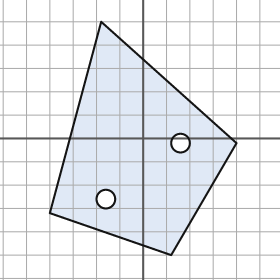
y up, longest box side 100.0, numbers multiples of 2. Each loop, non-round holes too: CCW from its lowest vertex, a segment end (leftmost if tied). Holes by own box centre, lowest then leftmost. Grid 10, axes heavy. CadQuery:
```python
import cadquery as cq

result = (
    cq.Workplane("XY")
    .moveTo(12.0, -50.0)
    .lineTo(40.0, -2.0)
    .lineTo(-18.0, 50.0)
    .lineTo(-40.0, -32.0)
    .close()
    .moveTo(-16.0, -26.0)
    .circle(4.0)
    .moveTo(16.0, -2.0)
    .circle(4.0)
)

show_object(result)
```